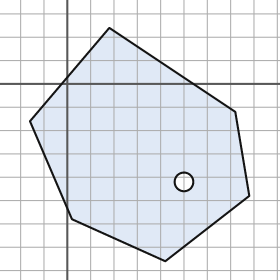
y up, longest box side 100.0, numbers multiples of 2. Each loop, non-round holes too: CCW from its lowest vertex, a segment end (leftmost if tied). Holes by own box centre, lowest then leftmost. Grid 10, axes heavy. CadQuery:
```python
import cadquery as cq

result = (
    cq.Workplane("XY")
    .moveTo(42.0, -76.0)
    .lineTo(78.0, -48.0)
    .lineTo(72.0, -12.0)
    .lineTo(18.0, 24.0)
    .lineTo(-16.0, -16.0)
    .lineTo(2.0, -58.0)
    .close()
    .moveTo(50.0, -42.0)
    .circle(4.0)
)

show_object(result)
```